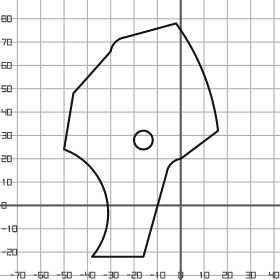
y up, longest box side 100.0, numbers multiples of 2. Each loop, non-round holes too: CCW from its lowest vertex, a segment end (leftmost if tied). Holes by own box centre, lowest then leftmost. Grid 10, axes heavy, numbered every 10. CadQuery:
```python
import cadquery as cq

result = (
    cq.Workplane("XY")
    .moveTo(-38.0, -22.0)
    .lineTo(-16.0, -22.0)
    .lineTo(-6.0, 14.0)
    .threePointArc((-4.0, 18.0), (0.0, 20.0))
    .lineTo(16.0, 32.0)
    .threePointArc((10.0, 56.0), (-2.0, 78.0))
    .lineTo(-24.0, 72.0)
    .threePointArc((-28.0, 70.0), (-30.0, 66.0))
    .lineTo(-46.0, 48.0)
    .lineTo(-50.0, 24.0)
    .threePointArc((-32.0, 4.0), (-38.0, -22.0))
    .close()
    .moveTo(-16.0, 28.0)
    .circle(4.0)
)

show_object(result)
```